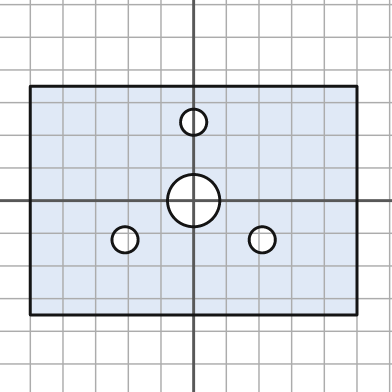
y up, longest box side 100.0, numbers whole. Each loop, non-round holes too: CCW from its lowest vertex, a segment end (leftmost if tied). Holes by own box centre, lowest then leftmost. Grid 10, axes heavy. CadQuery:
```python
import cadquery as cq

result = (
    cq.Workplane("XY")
    .moveTo(-50.0, -35.0)
    .lineTo(50.0, -35.0)
    .lineTo(50.0, 35.0)
    .lineTo(-50.0, 35.0)
    .close()
    .moveTo(-21.0, -12.0)
    .circle(4.0)
    .moveTo(21.0, -12.0)
    .circle(4.0)
    .moveTo(0.0, 0.0)
    .circle(8.0)
    .moveTo(0.0, 24.0)
    .circle(4.0)
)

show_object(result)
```